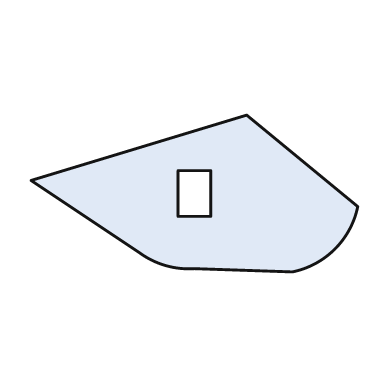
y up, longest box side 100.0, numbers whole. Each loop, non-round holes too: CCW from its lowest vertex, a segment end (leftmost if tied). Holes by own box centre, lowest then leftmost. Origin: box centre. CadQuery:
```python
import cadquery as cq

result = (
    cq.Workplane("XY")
    .moveTo(30.0, -24.0)
    .threePointArc((43.0, -17.0), (50.0, -4.0))
    .lineTo(16.0, 24.0)
    .lineTo(-50.0, 4.0)
    .lineTo(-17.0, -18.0)
    .threePointArc((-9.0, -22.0), (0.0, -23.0))
    .close()
    .moveTo(-5.0, -7.0)
    .lineTo(5.0, -7.0)
    .lineTo(5.0, 7.0)
    .lineTo(-5.0, 7.0)
    .close()
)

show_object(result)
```